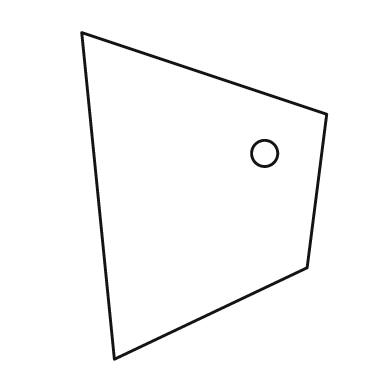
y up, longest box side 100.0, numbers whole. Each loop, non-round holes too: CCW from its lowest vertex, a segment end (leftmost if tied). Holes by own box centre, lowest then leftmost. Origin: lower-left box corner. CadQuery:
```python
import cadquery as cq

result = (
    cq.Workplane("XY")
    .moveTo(10.0, 0.0)
    .lineTo(69.0, 28.0)
    .lineTo(75.0, 75.0)
    .lineTo(0.0, 100.0)
    .close()
    .moveTo(56.0, 63.0)
    .circle(4.0)
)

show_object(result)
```